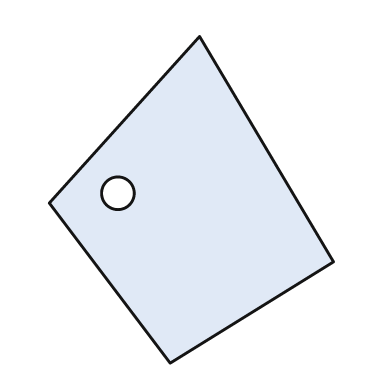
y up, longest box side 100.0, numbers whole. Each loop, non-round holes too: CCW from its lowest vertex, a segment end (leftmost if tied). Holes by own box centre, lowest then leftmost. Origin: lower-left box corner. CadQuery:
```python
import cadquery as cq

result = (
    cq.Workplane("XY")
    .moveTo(37.0, 0.0)
    .lineTo(87.0, 31.0)
    .lineTo(46.0, 100.0)
    .lineTo(0.0, 49.0)
    .close()
    .moveTo(21.0, 52.0)
    .circle(5.0)
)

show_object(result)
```